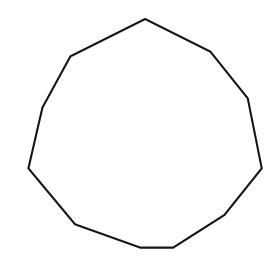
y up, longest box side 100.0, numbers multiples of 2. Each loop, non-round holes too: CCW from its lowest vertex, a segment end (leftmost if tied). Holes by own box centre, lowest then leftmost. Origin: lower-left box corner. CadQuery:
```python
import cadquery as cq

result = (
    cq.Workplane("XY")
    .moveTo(48.0, 0.0)
    .lineTo(62.0, 0.0)
    .lineTo(84.0, 14.0)
    .lineTo(100.0, 34.0)
    .lineTo(94.0, 64.0)
    .lineTo(78.0, 84.0)
    .lineTo(50.0, 98.0)
    .lineTo(18.0, 82.0)
    .lineTo(6.0, 60.0)
    .lineTo(0.0, 34.0)
    .lineTo(20.0, 10.0)
    .close()
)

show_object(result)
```